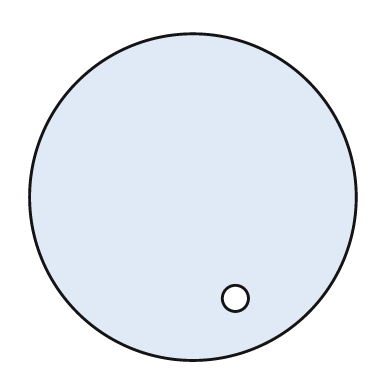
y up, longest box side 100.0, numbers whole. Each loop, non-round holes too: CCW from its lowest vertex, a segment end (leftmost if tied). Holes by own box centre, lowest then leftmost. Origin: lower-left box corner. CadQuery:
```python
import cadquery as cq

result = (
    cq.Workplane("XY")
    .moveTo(50.0, 50.0)
    .circle(50.0)
    .moveTo(63.0, 19.0)
    .circle(4.0)
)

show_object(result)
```